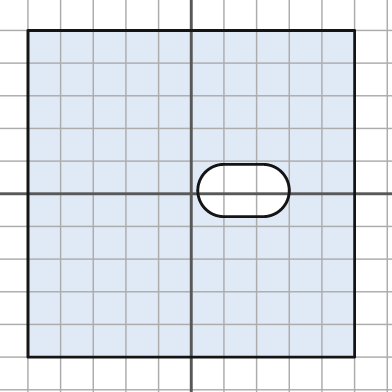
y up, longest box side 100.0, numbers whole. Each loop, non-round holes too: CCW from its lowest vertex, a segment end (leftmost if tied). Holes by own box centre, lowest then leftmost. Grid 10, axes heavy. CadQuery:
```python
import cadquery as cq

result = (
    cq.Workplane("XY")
    .moveTo(-50.0, -50.0)
    .lineTo(50.0, -50.0)
    .lineTo(50.0, 50.0)
    .lineTo(-50.0, 50.0)
    .close()
    .moveTo(10.0, -7.0)
    .lineTo(22.0, -7.0)
    .threePointArc((30.0, 1.0), (22.0, 9.0))
    .lineTo(10.0, 9.0)
    .threePointArc((2.0, 1.0), (10.0, -7.0))
    .close()
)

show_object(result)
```